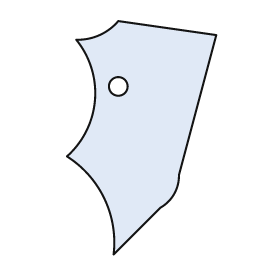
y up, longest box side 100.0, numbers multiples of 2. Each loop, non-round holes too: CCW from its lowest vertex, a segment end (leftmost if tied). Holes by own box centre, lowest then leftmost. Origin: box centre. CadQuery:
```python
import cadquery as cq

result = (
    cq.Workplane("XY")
    .moveTo(-12.0, -50.0)
    .lineTo(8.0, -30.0)
    .threePointArc((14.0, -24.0), (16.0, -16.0))
    .lineTo(32.0, 44.0)
    .lineTo(-10.0, 50.0)
    .threePointArc((-18.0, 44.0), (-28.0, 42.0))
    .threePointArc((-20.0, 16.0), (-32.0, -8.0))
    .threePointArc((-16.0, -26.0), (-12.0, -50.0))
    .close()
    .moveTo(-10.0, 22.0)
    .circle(4.0)
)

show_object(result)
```